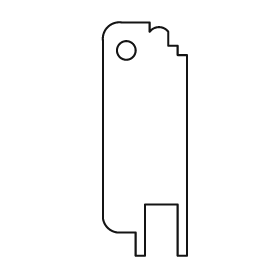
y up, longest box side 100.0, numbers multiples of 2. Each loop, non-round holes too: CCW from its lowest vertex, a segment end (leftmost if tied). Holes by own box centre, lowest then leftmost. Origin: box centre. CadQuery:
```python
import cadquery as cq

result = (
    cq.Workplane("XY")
    .moveTo(-4.0, -50.0)
    .lineTo(0.0, -50.0)
    .lineTo(0.0, -28.0)
    .lineTo(14.0, -28.0)
    .lineTo(14.0, -50.0)
    .lineTo(18.0, -50.0)
    .lineTo(18.0, 36.0)
    .lineTo(14.0, 36.0)
    .lineTo(14.0, 40.0)
    .lineTo(10.0, 40.0)
    .lineTo(10.0, 46.0)
    .threePointArc((6.0, 48.0), (2.0, 46.0))
    .lineTo(2.0, 50.0)
    .lineTo(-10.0, 50.0)
    .threePointArc((-16.0, 48.0), (-18.0, 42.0))
    .lineTo(-18.0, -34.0)
    .threePointArc((-16.0, -38.0), (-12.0, -40.0))
    .lineTo(-4.0, -40.0)
    .close()
    .moveTo(-8.0, 38.0)
    .circle(4.0)
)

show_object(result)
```